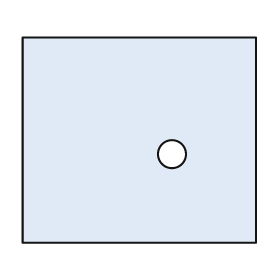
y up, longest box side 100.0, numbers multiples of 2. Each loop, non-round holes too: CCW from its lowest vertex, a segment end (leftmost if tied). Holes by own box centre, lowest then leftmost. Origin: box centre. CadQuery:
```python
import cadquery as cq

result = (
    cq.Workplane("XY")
    .moveTo(-50.0, -44.0)
    .lineTo(50.0, -44.0)
    .lineTo(50.0, 44.0)
    .lineTo(-50.0, 44.0)
    .close()
    .moveTo(14.0, -6.0)
    .circle(6.0)
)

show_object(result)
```